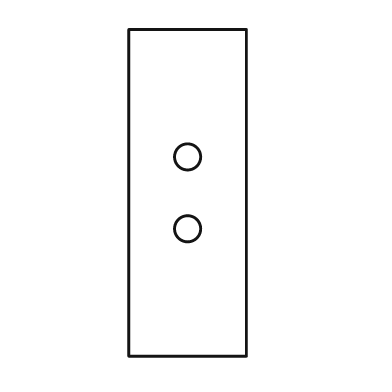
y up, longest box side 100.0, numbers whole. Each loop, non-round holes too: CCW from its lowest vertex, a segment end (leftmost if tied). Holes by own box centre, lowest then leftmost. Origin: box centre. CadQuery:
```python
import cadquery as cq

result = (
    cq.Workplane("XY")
    .moveTo(-18.0, -50.0)
    .lineTo(18.0, -50.0)
    .lineTo(18.0, 50.0)
    .lineTo(-18.0, 50.0)
    .close()
    .moveTo(0.0, -11.0)
    .circle(4.0)
    .moveTo(0.0, 11.0)
    .circle(4.0)
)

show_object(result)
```